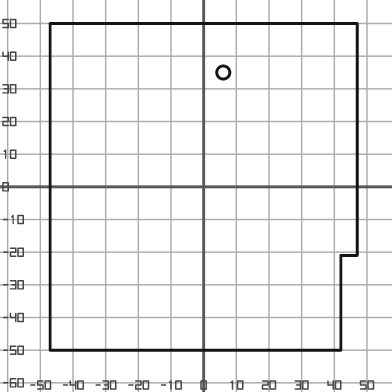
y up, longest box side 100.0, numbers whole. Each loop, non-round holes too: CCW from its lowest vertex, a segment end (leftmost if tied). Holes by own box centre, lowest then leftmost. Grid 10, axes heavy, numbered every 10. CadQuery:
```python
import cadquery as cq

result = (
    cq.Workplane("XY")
    .moveTo(-47.0, -50.0)
    .lineTo(42.0, -50.0)
    .lineTo(42.0, -21.0)
    .lineTo(47.0, -21.0)
    .lineTo(47.0, 50.0)
    .lineTo(-47.0, 50.0)
    .close()
    .moveTo(6.0, 35.0)
    .circle(2.0)
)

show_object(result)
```